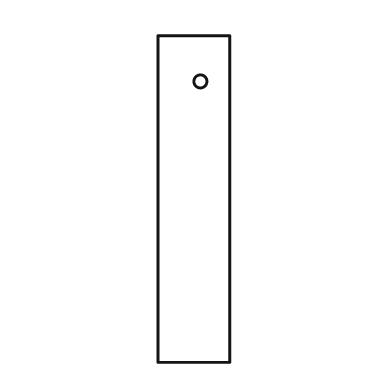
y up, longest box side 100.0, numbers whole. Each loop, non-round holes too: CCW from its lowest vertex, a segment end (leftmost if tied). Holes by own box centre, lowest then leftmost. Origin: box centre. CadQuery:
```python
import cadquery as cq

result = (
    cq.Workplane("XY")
    .moveTo(-11.0, -50.0)
    .lineTo(11.0, -50.0)
    .lineTo(11.0, 50.0)
    .lineTo(-11.0, 50.0)
    .close()
    .moveTo(2.0, 36.0)
    .circle(2.0)
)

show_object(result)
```